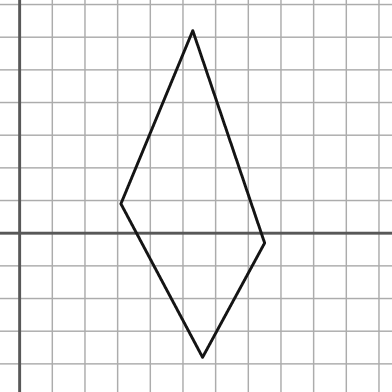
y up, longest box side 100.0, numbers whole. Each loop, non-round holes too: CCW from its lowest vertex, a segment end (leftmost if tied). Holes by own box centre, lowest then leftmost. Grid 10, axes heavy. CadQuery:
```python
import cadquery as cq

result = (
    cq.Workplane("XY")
    .moveTo(56.0, -38.0)
    .lineTo(75.0, -3.0)
    .lineTo(53.0, 62.0)
    .lineTo(31.0, 9.0)
    .close()
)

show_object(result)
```